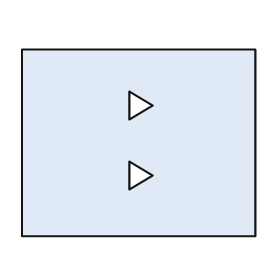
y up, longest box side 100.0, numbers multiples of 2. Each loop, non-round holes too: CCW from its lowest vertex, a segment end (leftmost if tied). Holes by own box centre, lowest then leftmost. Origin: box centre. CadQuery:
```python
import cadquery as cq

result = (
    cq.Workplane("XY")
    .moveTo(-50.0, -40.0)
    .lineTo(50.0, -40.0)
    .lineTo(50.0, 40.0)
    .lineTo(-50.0, 40.0)
    .close()
    .moveTo(-4.0, -20.0)
    .lineTo(6.0, -14.0)
    .lineTo(-4.0, -8.0)
    .close()
    .moveTo(-4.0, 10.0)
    .lineTo(6.0, 16.0)
    .lineTo(-4.0, 22.0)
    .close()
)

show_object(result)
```